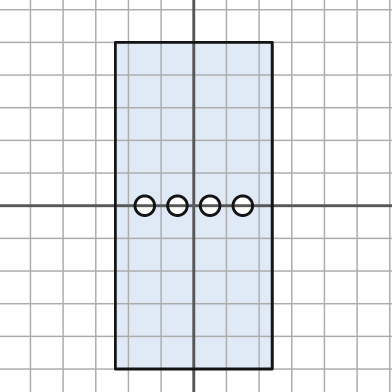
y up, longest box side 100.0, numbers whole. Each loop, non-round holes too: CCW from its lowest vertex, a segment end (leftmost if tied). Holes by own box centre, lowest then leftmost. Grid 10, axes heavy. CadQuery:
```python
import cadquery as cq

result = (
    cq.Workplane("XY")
    .moveTo(-24.0, -50.0)
    .lineTo(24.0, -50.0)
    .lineTo(24.0, 50.0)
    .lineTo(-24.0, 50.0)
    .close()
    .moveTo(-15.0, 0.0)
    .circle(3.0)
    .moveTo(-5.0, 0.0)
    .circle(3.0)
    .moveTo(5.0, 0.0)
    .circle(3.0)
    .moveTo(15.0, 0.0)
    .circle(3.0)
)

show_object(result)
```